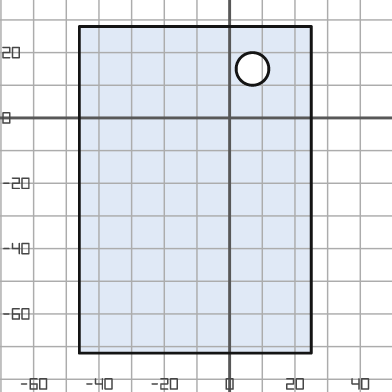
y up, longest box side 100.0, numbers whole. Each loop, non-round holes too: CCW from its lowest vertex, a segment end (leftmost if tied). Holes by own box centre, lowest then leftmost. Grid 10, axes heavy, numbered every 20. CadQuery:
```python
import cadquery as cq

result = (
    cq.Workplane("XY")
    .moveTo(-46.0, -72.0)
    .lineTo(25.0, -72.0)
    .lineTo(25.0, 28.0)
    .lineTo(-46.0, 28.0)
    .close()
    .moveTo(7.0, 15.0)
    .circle(5.0)
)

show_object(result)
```